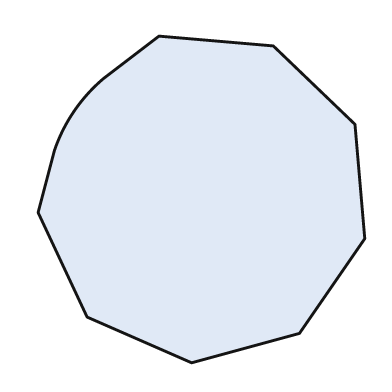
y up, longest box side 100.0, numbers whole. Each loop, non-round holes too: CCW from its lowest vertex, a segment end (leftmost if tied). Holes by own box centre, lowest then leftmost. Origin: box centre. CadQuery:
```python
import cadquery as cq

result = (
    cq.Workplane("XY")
    .moveTo(-3.0, -50.0)
    .lineTo(30.0, -41.0)
    .lineTo(50.0, -12.0)
    .lineTo(47.0, 23.0)
    .lineTo(22.0, 47.0)
    .lineTo(-13.0, 50.0)
    .lineTo(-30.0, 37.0)
    .threePointArc((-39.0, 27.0), (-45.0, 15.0))
    .lineTo(-50.0, -4.0)
    .lineTo(-35.0, -36.0)
    .close()
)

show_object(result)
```